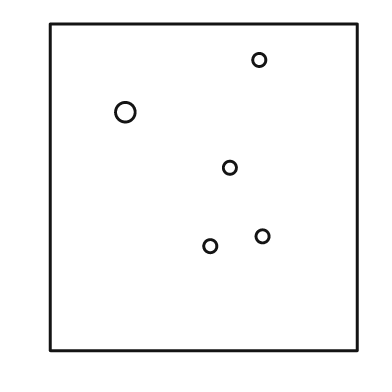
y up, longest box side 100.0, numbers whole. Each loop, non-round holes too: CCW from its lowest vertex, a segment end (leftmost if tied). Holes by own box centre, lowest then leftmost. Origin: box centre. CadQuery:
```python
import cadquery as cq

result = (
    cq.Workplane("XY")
    .moveTo(-47.0, -50.0)
    .lineTo(47.0, -50.0)
    .lineTo(47.0, 50.0)
    .lineTo(-47.0, 50.0)
    .close()
    .moveTo(2.0, -18.0)
    .circle(2.0)
    .moveTo(18.0, -15.0)
    .circle(2.0)
    .moveTo(8.0, 6.0)
    .circle(2.0)
    .moveTo(-24.0, 23.0)
    .circle(3.0)
    .moveTo(17.0, 39.0)
    .circle(2.0)
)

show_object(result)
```